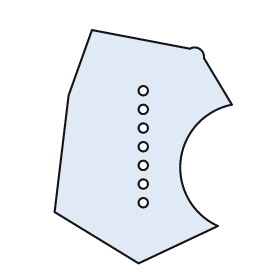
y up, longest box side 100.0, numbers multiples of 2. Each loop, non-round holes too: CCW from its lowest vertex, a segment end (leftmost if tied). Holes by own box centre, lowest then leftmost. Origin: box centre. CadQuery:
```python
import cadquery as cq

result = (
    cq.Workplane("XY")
    .moveTo(-2.0, -50.0)
    .lineTo(32.0, -34.0)
    .threePointArc((16.0, -6.0), (38.0, 18.0))
    .lineTo(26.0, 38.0)
    .threePointArc((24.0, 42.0), (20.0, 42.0))
    .lineTo(-22.0, 50.0)
    .lineTo(-32.0, 22.0)
    .lineTo(-38.0, -28.0)
    .close()
    .moveTo(0.0, -24.0)
    .circle(2.0)
    .moveTo(0.0, -16.0)
    .circle(2.0)
    .moveTo(0.0, -8.0)
    .circle(2.0)
    .moveTo(0.0, 0.0)
    .circle(2.0)
    .moveTo(0.0, 8.0)
    .circle(2.0)
    .moveTo(0.0, 16.0)
    .circle(2.0)
    .moveTo(0.0, 24.0)
    .circle(2.0)
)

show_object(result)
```